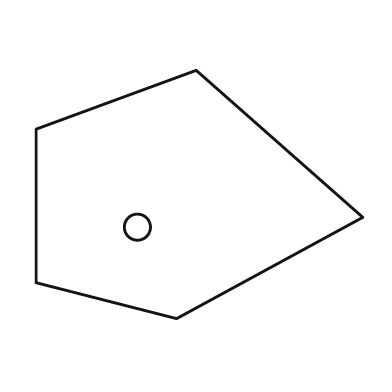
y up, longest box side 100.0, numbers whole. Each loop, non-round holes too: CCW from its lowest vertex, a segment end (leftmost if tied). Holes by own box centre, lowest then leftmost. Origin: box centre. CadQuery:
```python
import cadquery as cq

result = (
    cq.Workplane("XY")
    .moveTo(-7.0, -38.0)
    .lineTo(50.0, -7.0)
    .lineTo(-1.0, 38.0)
    .lineTo(-50.0, 20.0)
    .lineTo(-50.0, -27.0)
    .close()
    .moveTo(-19.0, -10.0)
    .circle(4.0)
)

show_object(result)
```